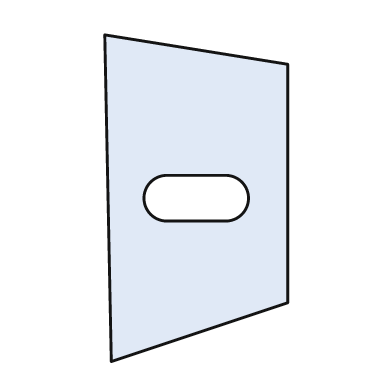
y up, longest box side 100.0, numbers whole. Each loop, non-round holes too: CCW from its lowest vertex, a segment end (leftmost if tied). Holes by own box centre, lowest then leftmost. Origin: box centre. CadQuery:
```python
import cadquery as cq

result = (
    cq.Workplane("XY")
    .moveTo(-26.0, -50.0)
    .lineTo(28.0, -32.0)
    .lineTo(28.0, 41.0)
    .lineTo(-28.0, 50.0)
    .close()
    .moveTo(-9.0, -7.0)
    .lineTo(9.0, -7.0)
    .threePointArc((16.0, 0.0), (9.0, 7.0))
    .lineTo(-9.0, 7.0)
    .threePointArc((-16.0, 0.0), (-9.0, -7.0))
    .close()
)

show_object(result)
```